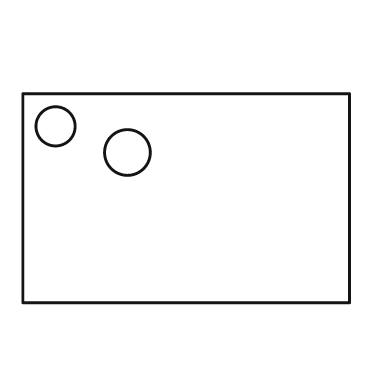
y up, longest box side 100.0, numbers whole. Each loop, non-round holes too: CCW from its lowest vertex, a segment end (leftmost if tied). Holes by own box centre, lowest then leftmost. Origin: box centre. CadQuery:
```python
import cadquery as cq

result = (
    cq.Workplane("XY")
    .moveTo(-50.0, -32.0)
    .lineTo(50.0, -32.0)
    .lineTo(50.0, 32.0)
    .lineTo(-50.0, 32.0)
    .close()
    .moveTo(-18.0, 14.0)
    .circle(7.0)
    .moveTo(-40.0, 22.0)
    .circle(6.0)
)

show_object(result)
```